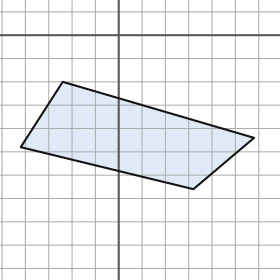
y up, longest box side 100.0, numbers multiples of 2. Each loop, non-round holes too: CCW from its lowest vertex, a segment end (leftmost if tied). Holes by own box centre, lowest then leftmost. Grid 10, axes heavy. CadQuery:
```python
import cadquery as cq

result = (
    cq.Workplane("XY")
    .moveTo(32.0, -66.0)
    .lineTo(58.0, -44.0)
    .lineTo(-24.0, -20.0)
    .lineTo(-42.0, -48.0)
    .close()
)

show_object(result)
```